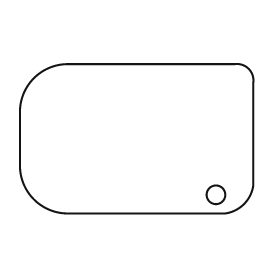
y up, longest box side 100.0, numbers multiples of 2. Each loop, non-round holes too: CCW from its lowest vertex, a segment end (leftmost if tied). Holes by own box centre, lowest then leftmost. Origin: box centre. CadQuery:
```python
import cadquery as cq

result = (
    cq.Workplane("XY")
    .moveTo(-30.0, -32.0)
    .lineTo(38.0, -32.0)
    .threePointArc((46.0, -28.0), (50.0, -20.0))
    .lineTo(50.0, 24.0)
    .threePointArc((48.0, 30.0), (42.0, 32.0))
    .lineTo(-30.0, 32.0)
    .threePointArc((-44.0, 26.0), (-50.0, 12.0))
    .lineTo(-50.0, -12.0)
    .threePointArc((-44.0, -26.0), (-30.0, -32.0))
    .close()
    .moveTo(34.0, -24.0)
    .circle(4.0)
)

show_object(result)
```